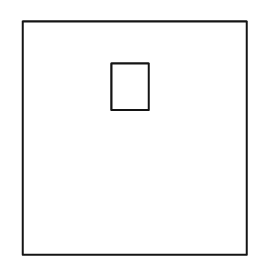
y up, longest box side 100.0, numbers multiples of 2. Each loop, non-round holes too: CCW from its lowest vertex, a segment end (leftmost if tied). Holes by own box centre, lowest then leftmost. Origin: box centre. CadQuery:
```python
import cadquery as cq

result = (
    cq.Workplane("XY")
    .moveTo(-48.0, -50.0)
    .lineTo(48.0, -50.0)
    .lineTo(48.0, 50.0)
    .lineTo(-48.0, 50.0)
    .close()
    .moveTo(-10.0, 12.0)
    .lineTo(6.0, 12.0)
    .lineTo(6.0, 32.0)
    .lineTo(-10.0, 32.0)
    .close()
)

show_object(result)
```